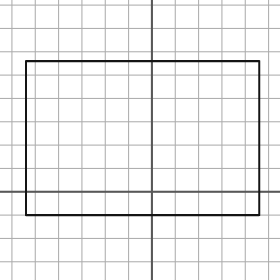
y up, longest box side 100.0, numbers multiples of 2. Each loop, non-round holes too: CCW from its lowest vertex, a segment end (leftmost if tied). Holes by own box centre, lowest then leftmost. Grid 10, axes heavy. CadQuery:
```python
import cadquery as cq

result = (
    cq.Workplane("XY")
    .moveTo(-54.0, -10.0)
    .lineTo(46.0, -10.0)
    .lineTo(46.0, 56.0)
    .lineTo(-54.0, 56.0)
    .close()
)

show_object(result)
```